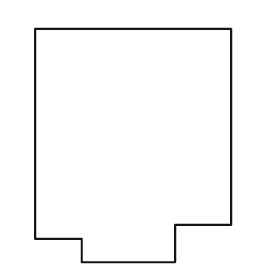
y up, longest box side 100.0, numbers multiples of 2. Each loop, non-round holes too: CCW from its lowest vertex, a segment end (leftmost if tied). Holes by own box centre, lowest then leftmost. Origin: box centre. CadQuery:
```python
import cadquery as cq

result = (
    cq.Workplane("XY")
    .moveTo(-22.0, -50.0)
    .lineTo(18.0, -50.0)
    .lineTo(18.0, -34.0)
    .lineTo(42.0, -34.0)
    .lineTo(42.0, 50.0)
    .lineTo(-42.0, 50.0)
    .lineTo(-42.0, -40.0)
    .lineTo(-22.0, -40.0)
    .close()
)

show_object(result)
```